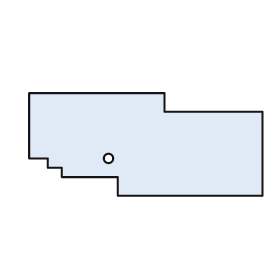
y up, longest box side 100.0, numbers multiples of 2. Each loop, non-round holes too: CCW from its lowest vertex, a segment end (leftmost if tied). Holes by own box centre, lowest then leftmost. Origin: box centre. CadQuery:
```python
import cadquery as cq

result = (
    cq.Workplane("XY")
    .moveTo(-12.0, -22.0)
    .lineTo(50.0, -22.0)
    .lineTo(50.0, 14.0)
    .lineTo(8.0, 14.0)
    .lineTo(8.0, 22.0)
    .lineTo(-50.0, 22.0)
    .lineTo(-50.0, -6.0)
    .lineTo(-42.0, -6.0)
    .lineTo(-42.0, -10.0)
    .lineTo(-36.0, -10.0)
    .lineTo(-36.0, -14.0)
    .lineTo(-12.0, -14.0)
    .close()
    .moveTo(-16.0, -6.0)
    .circle(2.0)
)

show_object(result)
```